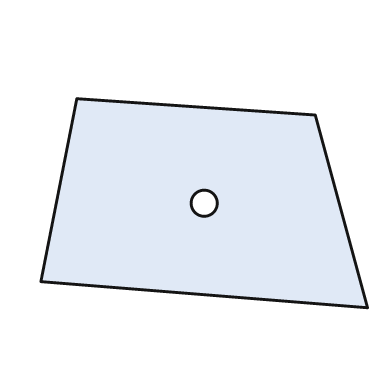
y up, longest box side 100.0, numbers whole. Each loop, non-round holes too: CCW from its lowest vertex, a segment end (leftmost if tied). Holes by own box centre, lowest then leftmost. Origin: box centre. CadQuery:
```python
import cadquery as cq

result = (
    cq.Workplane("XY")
    .moveTo(50.0, -32.0)
    .lineTo(34.0, 27.0)
    .lineTo(-39.0, 32.0)
    .lineTo(-50.0, -24.0)
    .close()
    .moveTo(0.0, 0.0)
    .circle(4.0)
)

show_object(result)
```